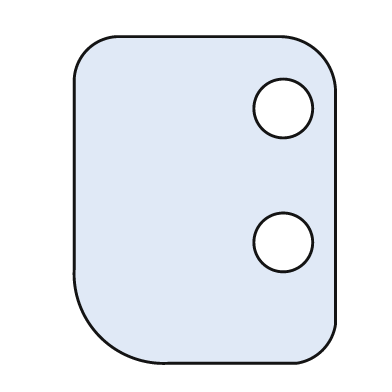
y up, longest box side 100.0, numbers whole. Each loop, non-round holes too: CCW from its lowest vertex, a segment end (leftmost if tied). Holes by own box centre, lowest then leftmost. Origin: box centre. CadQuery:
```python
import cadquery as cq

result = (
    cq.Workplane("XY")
    .moveTo(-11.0, -50.0)
    .lineTo(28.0, -50.0)
    .threePointArc((36.0, -46.0), (40.0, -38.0))
    .lineTo(40.0, 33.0)
    .threePointArc((35.0, 45.0), (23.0, 50.0))
    .lineTo(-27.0, 50.0)
    .threePointArc((-36.0, 46.0), (-40.0, 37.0))
    .lineTo(-40.0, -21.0)
    .threePointArc((-32.0, -42.0), (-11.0, -50.0))
    .close()
    .moveTo(24.0, -13.0)
    .circle(9.0)
    .moveTo(24.0, 28.0)
    .circle(9.0)
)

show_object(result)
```